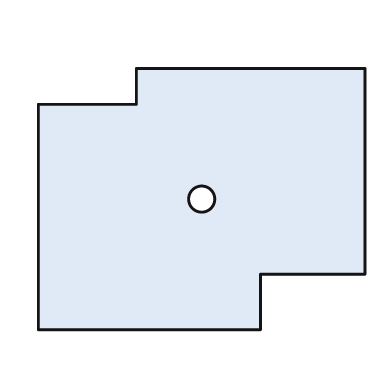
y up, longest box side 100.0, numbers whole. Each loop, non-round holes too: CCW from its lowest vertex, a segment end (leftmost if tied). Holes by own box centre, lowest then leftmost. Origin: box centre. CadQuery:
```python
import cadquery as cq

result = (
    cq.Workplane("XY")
    .moveTo(-50.0, -40.0)
    .lineTo(18.0, -40.0)
    .lineTo(18.0, -23.0)
    .lineTo(50.0, -23.0)
    .lineTo(50.0, 40.0)
    .lineTo(-20.0, 40.0)
    .lineTo(-20.0, 29.0)
    .lineTo(-50.0, 29.0)
    .close()
    .moveTo(0.0, 0.0)
    .circle(4.0)
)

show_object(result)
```